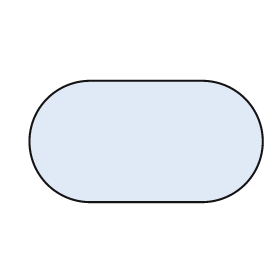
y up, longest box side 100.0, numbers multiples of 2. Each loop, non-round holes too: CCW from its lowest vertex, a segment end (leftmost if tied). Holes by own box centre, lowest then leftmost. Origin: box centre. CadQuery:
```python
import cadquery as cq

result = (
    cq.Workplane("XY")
    .moveTo(-24.0, -26.0)
    .lineTo(24.0, -26.0)
    .threePointArc((50.0, 0.0), (24.0, 26.0))
    .lineTo(-24.0, 26.0)
    .threePointArc((-50.0, 0.0), (-24.0, -26.0))
    .close()
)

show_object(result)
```